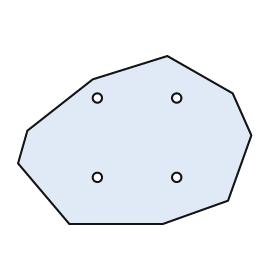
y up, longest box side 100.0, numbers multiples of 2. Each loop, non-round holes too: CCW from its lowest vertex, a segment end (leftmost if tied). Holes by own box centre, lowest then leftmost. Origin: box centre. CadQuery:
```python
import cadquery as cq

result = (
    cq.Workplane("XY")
    .moveTo(-28.0, -36.0)
    .lineTo(12.0, -36.0)
    .lineTo(40.0, -26.0)
    .lineTo(50.0, 2.0)
    .lineTo(42.0, 20.0)
    .lineTo(14.0, 36.0)
    .lineTo(-18.0, 26.0)
    .lineTo(-46.0, 4.0)
    .lineTo(-50.0, -10.0)
    .close()
    .moveTo(-16.0, -16.0)
    .circle(2.0)
    .moveTo(18.0, -16.0)
    .circle(2.0)
    .moveTo(-16.0, 18.0)
    .circle(2.0)
    .moveTo(18.0, 18.0)
    .circle(2.0)
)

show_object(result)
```